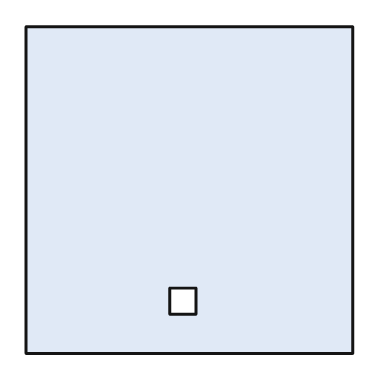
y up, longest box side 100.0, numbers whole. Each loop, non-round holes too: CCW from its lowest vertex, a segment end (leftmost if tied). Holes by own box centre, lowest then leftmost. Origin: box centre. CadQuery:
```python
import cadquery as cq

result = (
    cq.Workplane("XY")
    .moveTo(-50.0, -50.0)
    .lineTo(50.0, -50.0)
    .lineTo(50.0, 50.0)
    .lineTo(-50.0, 50.0)
    .close()
    .moveTo(-6.0, -38.0)
    .lineTo(2.0, -38.0)
    .lineTo(2.0, -30.0)
    .lineTo(-6.0, -30.0)
    .close()
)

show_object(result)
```